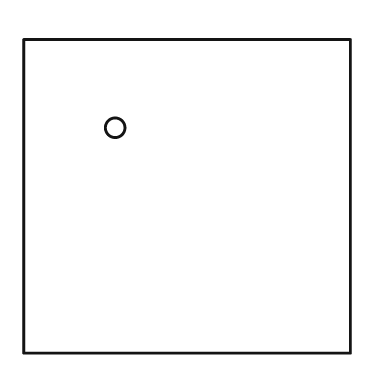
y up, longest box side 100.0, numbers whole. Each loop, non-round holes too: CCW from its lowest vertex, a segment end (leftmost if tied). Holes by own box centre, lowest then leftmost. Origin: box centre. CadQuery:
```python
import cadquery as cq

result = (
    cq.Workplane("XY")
    .moveTo(-50.0, -48.0)
    .lineTo(50.0, -48.0)
    .lineTo(50.0, 48.0)
    .lineTo(-50.0, 48.0)
    .close()
    .moveTo(-22.0, 21.0)
    .circle(3.0)
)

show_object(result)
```